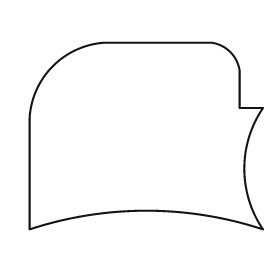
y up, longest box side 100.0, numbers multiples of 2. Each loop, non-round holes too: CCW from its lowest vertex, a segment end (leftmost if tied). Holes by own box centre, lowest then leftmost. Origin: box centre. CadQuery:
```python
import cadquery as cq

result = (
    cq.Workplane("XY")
    .moveTo(-50.0, -40.0)
    .threePointArc((0.0, -32.0), (50.0, -40.0))
    .threePointArc((42.0, -14.0), (50.0, 12.0))
    .lineTo(40.0, 12.0)
    .lineTo(40.0, 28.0)
    .threePointArc((36.0, 36.0), (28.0, 40.0))
    .lineTo(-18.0, 40.0)
    .threePointArc((-40.0, 30.0), (-50.0, 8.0))
    .close()
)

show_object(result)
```